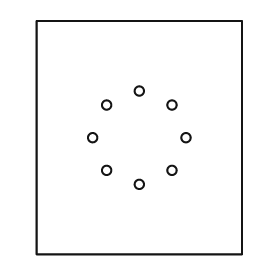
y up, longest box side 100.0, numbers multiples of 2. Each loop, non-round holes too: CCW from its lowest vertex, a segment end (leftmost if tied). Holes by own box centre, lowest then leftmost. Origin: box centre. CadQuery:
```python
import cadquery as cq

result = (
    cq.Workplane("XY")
    .moveTo(-44.0, -50.0)
    .lineTo(44.0, -50.0)
    .lineTo(44.0, 50.0)
    .lineTo(-44.0, 50.0)
    .close()
    .moveTo(0.0, -20.0)
    .circle(2.0)
    .moveTo(-14.0, -14.0)
    .circle(2.0)
    .moveTo(14.0, -14.0)
    .circle(2.0)
    .moveTo(-20.0, 0.0)
    .circle(2.0)
    .moveTo(20.0, 0.0)
    .circle(2.0)
    .moveTo(-14.0, 14.0)
    .circle(2.0)
    .moveTo(14.0, 14.0)
    .circle(2.0)
    .moveTo(0.0, 20.0)
    .circle(2.0)
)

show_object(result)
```